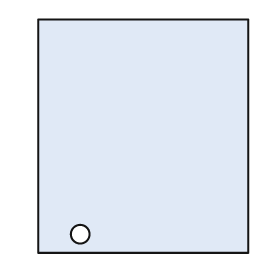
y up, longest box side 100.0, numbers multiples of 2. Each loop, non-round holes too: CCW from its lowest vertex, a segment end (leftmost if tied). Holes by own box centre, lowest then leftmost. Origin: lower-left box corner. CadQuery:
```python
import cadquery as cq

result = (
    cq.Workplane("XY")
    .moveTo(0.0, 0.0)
    .lineTo(90.0, 0.0)
    .lineTo(90.0, 100.0)
    .lineTo(0.0, 100.0)
    .close()
    .moveTo(18.0, 8.0)
    .circle(4.0)
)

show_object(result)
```